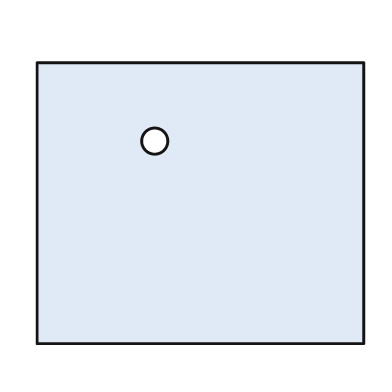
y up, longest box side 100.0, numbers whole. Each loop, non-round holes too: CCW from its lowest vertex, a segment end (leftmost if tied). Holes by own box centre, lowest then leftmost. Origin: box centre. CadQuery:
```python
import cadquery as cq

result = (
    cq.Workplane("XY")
    .moveTo(-50.0, -43.0)
    .lineTo(50.0, -43.0)
    .lineTo(50.0, 43.0)
    .lineTo(-50.0, 43.0)
    .close()
    .moveTo(-14.0, 19.0)
    .circle(4.0)
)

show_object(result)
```